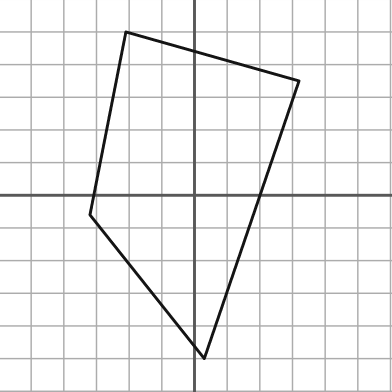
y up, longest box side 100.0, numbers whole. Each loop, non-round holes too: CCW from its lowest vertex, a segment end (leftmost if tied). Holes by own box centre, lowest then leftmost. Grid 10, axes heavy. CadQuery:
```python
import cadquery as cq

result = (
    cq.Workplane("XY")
    .moveTo(3.0, -50.0)
    .lineTo(32.0, 35.0)
    .lineTo(-21.0, 50.0)
    .lineTo(-32.0, -6.0)
    .close()
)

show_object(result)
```